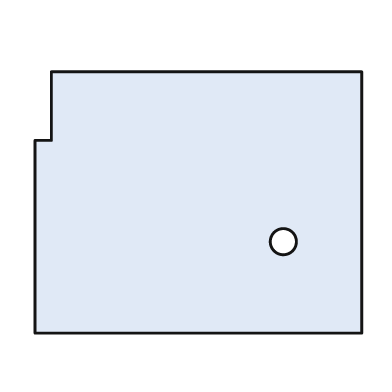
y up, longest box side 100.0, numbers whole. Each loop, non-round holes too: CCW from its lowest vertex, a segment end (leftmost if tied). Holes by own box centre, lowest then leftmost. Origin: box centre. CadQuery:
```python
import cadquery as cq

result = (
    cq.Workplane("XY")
    .moveTo(-50.0, -40.0)
    .lineTo(50.0, -40.0)
    .lineTo(50.0, 40.0)
    .lineTo(-45.0, 40.0)
    .lineTo(-45.0, 19.0)
    .lineTo(-50.0, 19.0)
    .close()
    .moveTo(26.0, -12.0)
    .circle(4.0)
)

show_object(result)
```